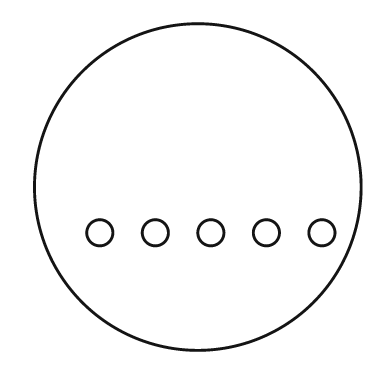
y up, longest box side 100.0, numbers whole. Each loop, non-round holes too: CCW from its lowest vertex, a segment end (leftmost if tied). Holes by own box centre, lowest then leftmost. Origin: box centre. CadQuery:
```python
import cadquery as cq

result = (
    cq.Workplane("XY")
    .moveTo(0.0, 0.0)
    .circle(50.0)
    .moveTo(-30.0, -14.0)
    .circle(4.0)
    .moveTo(-13.0, -14.0)
    .circle(4.0)
    .moveTo(4.0, -14.0)
    .circle(4.0)
    .moveTo(21.0, -14.0)
    .circle(4.0)
    .moveTo(38.0, -14.0)
    .circle(4.0)
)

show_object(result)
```